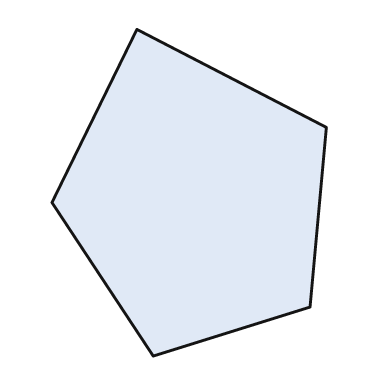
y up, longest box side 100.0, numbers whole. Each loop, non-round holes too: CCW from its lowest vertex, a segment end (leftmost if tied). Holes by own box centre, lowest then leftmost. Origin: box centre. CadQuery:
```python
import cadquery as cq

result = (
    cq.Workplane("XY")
    .moveTo(-11.0, -50.0)
    .lineTo(37.0, -35.0)
    .lineTo(42.0, 20.0)
    .lineTo(-16.0, 50.0)
    .lineTo(-42.0, -3.0)
    .close()
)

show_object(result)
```